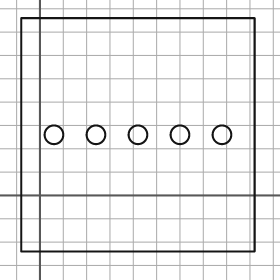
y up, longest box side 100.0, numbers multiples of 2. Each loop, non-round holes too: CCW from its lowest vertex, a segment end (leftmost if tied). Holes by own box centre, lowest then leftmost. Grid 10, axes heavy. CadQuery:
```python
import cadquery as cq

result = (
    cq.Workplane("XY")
    .moveTo(-8.0, -24.0)
    .lineTo(92.0, -24.0)
    .lineTo(92.0, 76.0)
    .lineTo(-8.0, 76.0)
    .close()
    .moveTo(6.0, 26.0)
    .circle(4.0)
    .moveTo(24.0, 26.0)
    .circle(4.0)
    .moveTo(42.0, 26.0)
    .circle(4.0)
    .moveTo(60.0, 26.0)
    .circle(4.0)
    .moveTo(78.0, 26.0)
    .circle(4.0)
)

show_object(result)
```